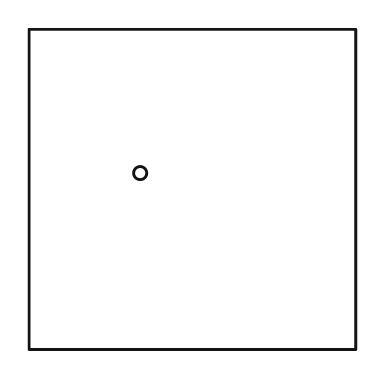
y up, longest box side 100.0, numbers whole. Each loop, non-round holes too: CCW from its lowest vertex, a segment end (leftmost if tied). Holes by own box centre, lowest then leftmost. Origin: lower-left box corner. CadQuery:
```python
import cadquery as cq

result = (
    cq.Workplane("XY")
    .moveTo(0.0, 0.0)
    .lineTo(100.0, 0.0)
    .lineTo(100.0, 98.0)
    .lineTo(0.0, 98.0)
    .close()
    .moveTo(34.0, 54.0)
    .circle(2.0)
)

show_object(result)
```